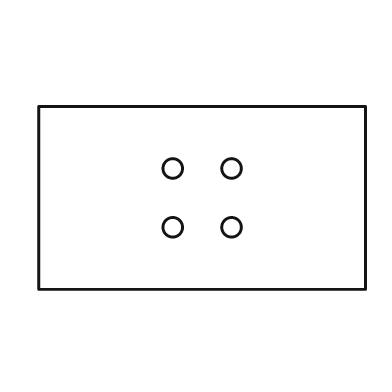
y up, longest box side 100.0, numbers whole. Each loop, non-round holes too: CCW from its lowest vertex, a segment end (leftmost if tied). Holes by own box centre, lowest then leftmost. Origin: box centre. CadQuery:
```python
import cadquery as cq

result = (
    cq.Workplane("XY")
    .moveTo(-50.0, -28.0)
    .lineTo(50.0, -28.0)
    .lineTo(50.0, 28.0)
    .lineTo(-50.0, 28.0)
    .close()
    .moveTo(-9.0, -9.0)
    .circle(3.0)
    .moveTo(9.0, -9.0)
    .circle(3.0)
    .moveTo(-9.0, 9.0)
    .circle(3.0)
    .moveTo(9.0, 9.0)
    .circle(3.0)
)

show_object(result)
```